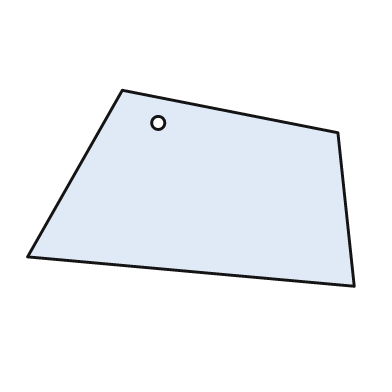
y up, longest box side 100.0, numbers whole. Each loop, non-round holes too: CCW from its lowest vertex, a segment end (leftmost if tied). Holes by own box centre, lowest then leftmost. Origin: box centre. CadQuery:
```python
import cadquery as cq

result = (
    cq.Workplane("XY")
    .moveTo(50.0, -30.0)
    .lineTo(45.0, 17.0)
    .lineTo(-21.0, 30.0)
    .lineTo(-50.0, -21.0)
    .close()
    .moveTo(-10.0, 20.0)
    .circle(2.0)
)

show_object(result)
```